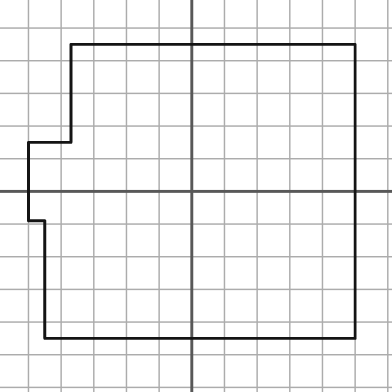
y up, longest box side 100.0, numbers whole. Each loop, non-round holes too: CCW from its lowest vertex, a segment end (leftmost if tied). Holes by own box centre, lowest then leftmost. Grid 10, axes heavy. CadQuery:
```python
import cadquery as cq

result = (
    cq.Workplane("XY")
    .moveTo(-45.0, -45.0)
    .lineTo(50.0, -45.0)
    .lineTo(50.0, 45.0)
    .lineTo(-37.0, 45.0)
    .lineTo(-37.0, 15.0)
    .lineTo(-50.0, 15.0)
    .lineTo(-50.0, -9.0)
    .lineTo(-45.0, -9.0)
    .close()
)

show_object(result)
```